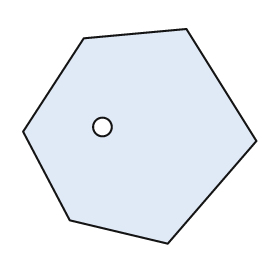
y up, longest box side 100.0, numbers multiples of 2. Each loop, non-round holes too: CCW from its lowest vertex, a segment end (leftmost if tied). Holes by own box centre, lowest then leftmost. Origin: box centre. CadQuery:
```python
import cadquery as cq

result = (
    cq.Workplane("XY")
    .moveTo(12.0, -46.0)
    .lineTo(50.0, -2.0)
    .lineTo(20.0, 46.0)
    .lineTo(-24.0, 42.0)
    .lineTo(-50.0, 2.0)
    .lineTo(-30.0, -36.0)
    .close()
    .moveTo(-16.0, 4.0)
    .circle(4.0)
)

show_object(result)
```